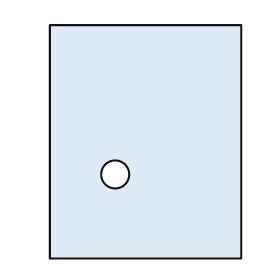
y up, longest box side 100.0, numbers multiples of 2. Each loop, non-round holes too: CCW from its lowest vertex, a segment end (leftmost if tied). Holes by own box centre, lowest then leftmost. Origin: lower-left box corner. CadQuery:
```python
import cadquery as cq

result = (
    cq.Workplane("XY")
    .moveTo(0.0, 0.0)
    .lineTo(82.0, 0.0)
    .lineTo(82.0, 100.0)
    .lineTo(0.0, 100.0)
    .close()
    .moveTo(28.0, 36.0)
    .circle(6.0)
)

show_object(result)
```